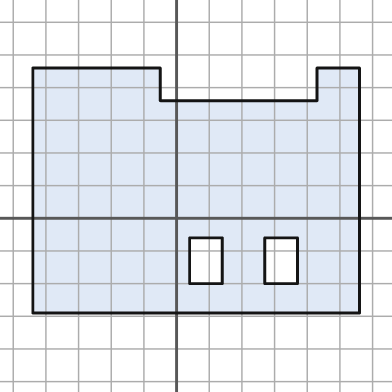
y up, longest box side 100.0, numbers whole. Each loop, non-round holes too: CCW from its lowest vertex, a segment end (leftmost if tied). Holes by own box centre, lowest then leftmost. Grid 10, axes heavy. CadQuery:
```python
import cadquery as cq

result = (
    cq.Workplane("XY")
    .moveTo(-44.0, -29.0)
    .lineTo(56.0, -29.0)
    .lineTo(56.0, 46.0)
    .lineTo(43.0, 46.0)
    .lineTo(43.0, 36.0)
    .lineTo(-5.0, 36.0)
    .lineTo(-5.0, 46.0)
    .lineTo(-44.0, 46.0)
    .close()
    .moveTo(4.0, -20.0)
    .lineTo(14.0, -20.0)
    .lineTo(14.0, -6.0)
    .lineTo(4.0, -6.0)
    .close()
    .moveTo(27.0, -20.0)
    .lineTo(37.0, -20.0)
    .lineTo(37.0, -6.0)
    .lineTo(27.0, -6.0)
    .close()
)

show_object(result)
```